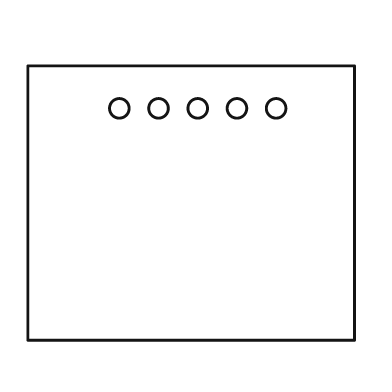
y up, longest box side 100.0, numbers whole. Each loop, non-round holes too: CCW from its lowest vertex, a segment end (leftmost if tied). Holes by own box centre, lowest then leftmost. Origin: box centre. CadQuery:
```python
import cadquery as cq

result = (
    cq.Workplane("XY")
    .moveTo(-50.0, -42.0)
    .lineTo(50.0, -42.0)
    .lineTo(50.0, 42.0)
    .lineTo(-50.0, 42.0)
    .close()
    .moveTo(-22.0, 29.0)
    .circle(3.0)
    .moveTo(-10.0, 29.0)
    .circle(3.0)
    .moveTo(2.0, 29.0)
    .circle(3.0)
    .moveTo(14.0, 29.0)
    .circle(3.0)
    .moveTo(26.0, 29.0)
    .circle(3.0)
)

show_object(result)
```